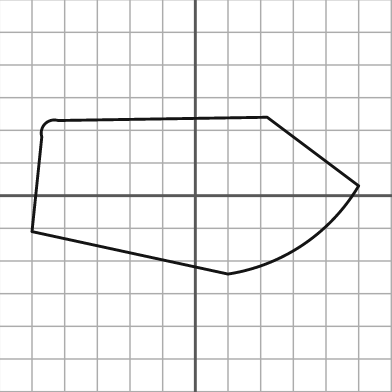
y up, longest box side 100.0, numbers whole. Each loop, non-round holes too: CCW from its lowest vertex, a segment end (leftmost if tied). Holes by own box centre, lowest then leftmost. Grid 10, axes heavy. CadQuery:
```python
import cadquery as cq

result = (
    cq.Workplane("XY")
    .moveTo(10.0, -24.0)
    .threePointArc((33.0, -15.0), (50.0, 3.0))
    .lineTo(22.0, 24.0)
    .lineTo(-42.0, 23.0)
    .threePointArc((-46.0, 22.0), (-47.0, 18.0))
    .lineTo(-50.0, -11.0)
    .close()
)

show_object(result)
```